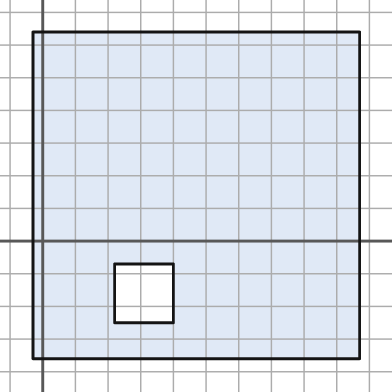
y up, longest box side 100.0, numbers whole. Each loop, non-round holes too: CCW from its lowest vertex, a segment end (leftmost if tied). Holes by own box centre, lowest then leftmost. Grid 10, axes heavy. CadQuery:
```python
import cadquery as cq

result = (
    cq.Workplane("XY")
    .moveTo(-3.0, -36.0)
    .lineTo(97.0, -36.0)
    .lineTo(97.0, 64.0)
    .lineTo(-3.0, 64.0)
    .close()
    .moveTo(22.0, -25.0)
    .lineTo(40.0, -25.0)
    .lineTo(40.0, -7.0)
    .lineTo(22.0, -7.0)
    .close()
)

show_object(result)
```